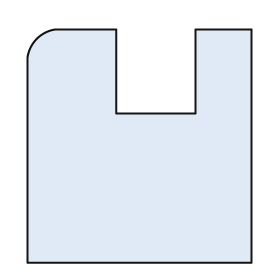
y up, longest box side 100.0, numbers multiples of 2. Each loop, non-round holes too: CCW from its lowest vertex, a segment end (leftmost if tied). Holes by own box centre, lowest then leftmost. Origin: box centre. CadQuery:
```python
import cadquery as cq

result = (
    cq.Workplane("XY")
    .moveTo(-48.0, -50.0)
    .lineTo(48.0, -50.0)
    .lineTo(48.0, 50.0)
    .lineTo(24.0, 50.0)
    .lineTo(24.0, 14.0)
    .lineTo(-10.0, 14.0)
    .lineTo(-10.0, 50.0)
    .lineTo(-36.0, 50.0)
    .threePointArc((-44.0, 46.0), (-48.0, 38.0))
    .close()
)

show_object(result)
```